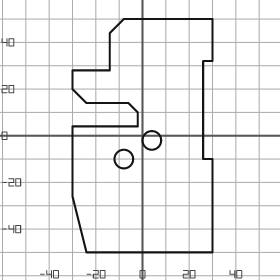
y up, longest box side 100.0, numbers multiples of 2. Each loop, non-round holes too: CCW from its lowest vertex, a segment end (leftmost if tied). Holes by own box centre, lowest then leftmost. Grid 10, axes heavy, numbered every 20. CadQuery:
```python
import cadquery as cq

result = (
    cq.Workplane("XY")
    .moveTo(-24.0, -50.0)
    .lineTo(30.0, -50.0)
    .lineTo(30.0, -10.0)
    .lineTo(26.0, -10.0)
    .lineTo(26.0, 32.0)
    .lineTo(30.0, 32.0)
    .lineTo(30.0, 50.0)
    .lineTo(-8.0, 50.0)
    .lineTo(-14.0, 44.0)
    .lineTo(-14.0, 28.0)
    .lineTo(-30.0, 28.0)
    .lineTo(-30.0, 20.0)
    .lineTo(-24.0, 14.0)
    .lineTo(-6.0, 14.0)
    .lineTo(-2.0, 10.0)
    .lineTo(-2.0, 4.0)
    .lineTo(-30.0, 4.0)
    .lineTo(-30.0, -26.0)
    .close()
    .moveTo(-8.0, -10.0)
    .circle(4.0)
    .moveTo(4.0, -2.0)
    .circle(4.0)
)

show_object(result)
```